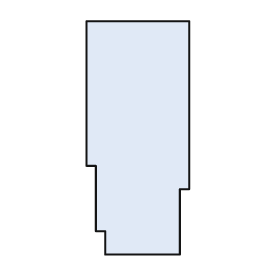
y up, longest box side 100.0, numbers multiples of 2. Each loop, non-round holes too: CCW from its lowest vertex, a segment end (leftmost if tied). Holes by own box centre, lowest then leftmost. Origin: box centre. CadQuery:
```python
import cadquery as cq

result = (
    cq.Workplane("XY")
    .moveTo(-14.0, -50.0)
    .lineTo(18.0, -50.0)
    .lineTo(18.0, -22.0)
    .lineTo(22.0, -22.0)
    .lineTo(22.0, 50.0)
    .lineTo(-22.0, 50.0)
    .lineTo(-22.0, -12.0)
    .lineTo(-18.0, -12.0)
    .lineTo(-18.0, -40.0)
    .lineTo(-14.0, -40.0)
    .close()
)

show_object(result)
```